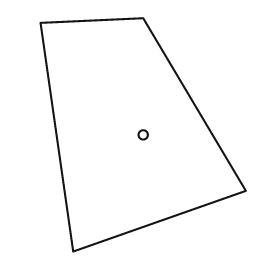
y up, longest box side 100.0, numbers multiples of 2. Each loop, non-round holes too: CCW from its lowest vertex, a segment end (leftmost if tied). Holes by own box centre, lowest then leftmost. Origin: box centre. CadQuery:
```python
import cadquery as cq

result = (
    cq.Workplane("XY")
    .moveTo(-30.0, -50.0)
    .lineTo(44.0, -24.0)
    .lineTo(0.0, 50.0)
    .lineTo(-44.0, 48.0)
    .close()
    .moveTo(0.0, 0.0)
    .circle(2.0)
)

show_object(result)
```